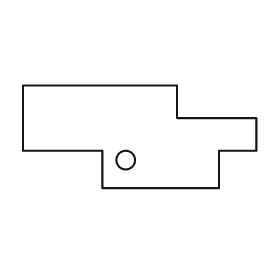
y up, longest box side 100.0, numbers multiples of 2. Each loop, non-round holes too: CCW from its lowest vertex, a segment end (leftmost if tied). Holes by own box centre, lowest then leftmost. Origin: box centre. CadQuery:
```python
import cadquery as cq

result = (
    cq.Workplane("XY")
    .moveTo(-16.0, -22.0)
    .lineTo(34.0, -22.0)
    .lineTo(34.0, -6.0)
    .lineTo(50.0, -6.0)
    .lineTo(50.0, 8.0)
    .lineTo(16.0, 8.0)
    .lineTo(16.0, 22.0)
    .lineTo(-50.0, 22.0)
    .lineTo(-50.0, -6.0)
    .lineTo(-16.0, -6.0)
    .close()
    .moveTo(-6.0, -10.0)
    .circle(4.0)
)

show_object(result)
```